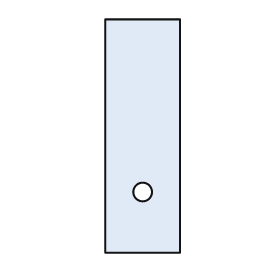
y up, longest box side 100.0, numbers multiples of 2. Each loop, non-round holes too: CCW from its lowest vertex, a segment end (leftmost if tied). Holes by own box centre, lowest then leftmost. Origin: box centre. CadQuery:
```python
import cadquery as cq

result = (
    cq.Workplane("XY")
    .moveTo(-16.0, -50.0)
    .lineTo(16.0, -50.0)
    .lineTo(16.0, 50.0)
    .lineTo(-16.0, 50.0)
    .close()
    .moveTo(0.0, -24.0)
    .circle(4.0)
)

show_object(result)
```